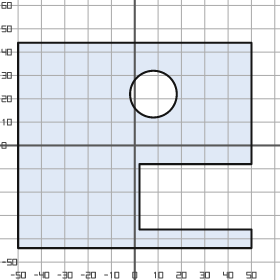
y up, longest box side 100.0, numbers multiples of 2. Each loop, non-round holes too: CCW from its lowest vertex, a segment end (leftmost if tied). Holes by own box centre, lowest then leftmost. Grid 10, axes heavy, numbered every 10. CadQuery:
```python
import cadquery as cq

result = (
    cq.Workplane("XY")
    .moveTo(-50.0, -44.0)
    .lineTo(50.0, -44.0)
    .lineTo(50.0, -36.0)
    .lineTo(2.0, -36.0)
    .lineTo(2.0, -8.0)
    .lineTo(50.0, -8.0)
    .lineTo(50.0, 44.0)
    .lineTo(-50.0, 44.0)
    .close()
    .moveTo(8.0, 22.0)
    .circle(10.0)
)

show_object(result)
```